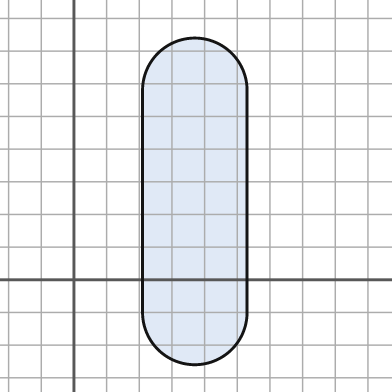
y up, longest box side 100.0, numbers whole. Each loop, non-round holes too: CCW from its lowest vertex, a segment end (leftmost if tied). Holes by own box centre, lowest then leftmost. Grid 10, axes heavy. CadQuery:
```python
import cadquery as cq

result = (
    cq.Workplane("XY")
    .moveTo(21.0, -10.0)
    .threePointArc((37.0, -26.0), (53.0, -10.0))
    .lineTo(53.0, 58.0)
    .threePointArc((37.0, 74.0), (21.0, 58.0))
    .close()
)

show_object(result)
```